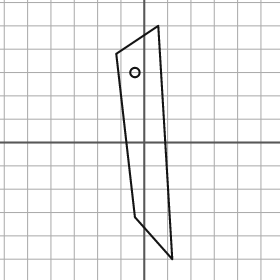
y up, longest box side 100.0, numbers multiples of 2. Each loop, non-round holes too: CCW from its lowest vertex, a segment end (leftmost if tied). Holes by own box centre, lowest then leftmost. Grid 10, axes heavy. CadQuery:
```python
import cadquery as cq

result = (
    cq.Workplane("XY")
    .moveTo(12.0, -50.0)
    .lineTo(6.0, 50.0)
    .lineTo(-12.0, 38.0)
    .lineTo(-4.0, -32.0)
    .close()
    .moveTo(-4.0, 30.0)
    .circle(2.0)
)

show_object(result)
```